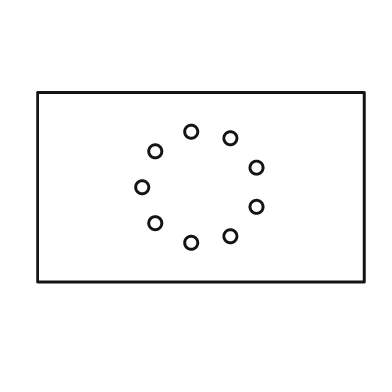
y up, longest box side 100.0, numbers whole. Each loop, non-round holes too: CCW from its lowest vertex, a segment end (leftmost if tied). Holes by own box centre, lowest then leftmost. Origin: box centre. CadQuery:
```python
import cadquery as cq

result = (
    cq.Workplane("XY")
    .moveTo(-50.0, -29.0)
    .lineTo(50.0, -29.0)
    .lineTo(50.0, 29.0)
    .lineTo(-50.0, 29.0)
    .close()
    .moveTo(-3.0, -17.0)
    .circle(2.0)
    .moveTo(9.0, -15.0)
    .circle(2.0)
    .moveTo(-14.0, -11.0)
    .circle(2.0)
    .moveTo(17.0, -6.0)
    .circle(2.0)
    .moveTo(-18.0, 0.0)
    .circle(2.0)
    .moveTo(17.0, 6.0)
    .circle(2.0)
    .moveTo(-14.0, 11.0)
    .circle(2.0)
    .moveTo(9.0, 15.0)
    .circle(2.0)
    .moveTo(-3.0, 17.0)
    .circle(2.0)
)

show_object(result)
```